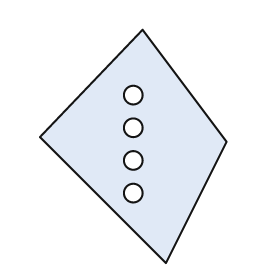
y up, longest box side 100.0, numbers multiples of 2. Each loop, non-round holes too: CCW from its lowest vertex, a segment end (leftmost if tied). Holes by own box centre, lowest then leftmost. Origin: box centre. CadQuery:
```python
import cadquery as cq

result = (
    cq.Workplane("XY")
    .moveTo(14.0, -50.0)
    .lineTo(40.0, 2.0)
    .lineTo(4.0, 50.0)
    .lineTo(-40.0, 4.0)
    .close()
    .moveTo(0.0, -20.0)
    .circle(4.0)
    .moveTo(0.0, -6.0)
    .circle(4.0)
    .moveTo(0.0, 8.0)
    .circle(4.0)
    .moveTo(0.0, 22.0)
    .circle(4.0)
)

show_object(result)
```